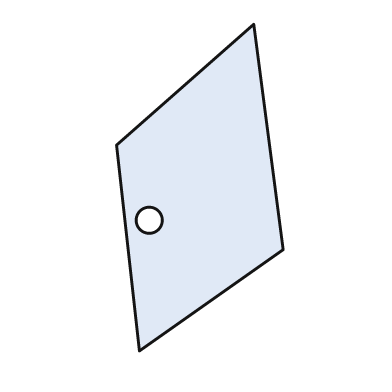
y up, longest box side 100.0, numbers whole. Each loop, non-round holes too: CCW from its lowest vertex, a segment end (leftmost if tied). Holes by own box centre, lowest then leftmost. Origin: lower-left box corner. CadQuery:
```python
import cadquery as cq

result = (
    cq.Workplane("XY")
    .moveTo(7.0, 0.0)
    .lineTo(51.0, 31.0)
    .lineTo(42.0, 100.0)
    .lineTo(0.0, 63.0)
    .close()
    .moveTo(10.0, 40.0)
    .circle(4.0)
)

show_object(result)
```